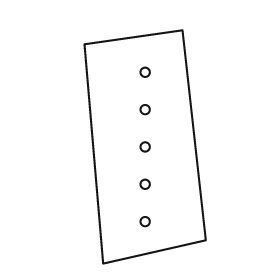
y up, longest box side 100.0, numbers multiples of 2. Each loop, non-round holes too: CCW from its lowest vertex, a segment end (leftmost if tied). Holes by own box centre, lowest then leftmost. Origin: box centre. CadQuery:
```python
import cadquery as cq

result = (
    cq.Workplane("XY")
    .moveTo(-18.0, -50.0)
    .lineTo(26.0, -40.0)
    .lineTo(16.0, 50.0)
    .lineTo(-26.0, 44.0)
    .close()
    .moveTo(0.0, -32.0)
    .circle(2.0)
    .moveTo(0.0, -16.0)
    .circle(2.0)
    .moveTo(0.0, 0.0)
    .circle(2.0)
    .moveTo(0.0, 16.0)
    .circle(2.0)
    .moveTo(0.0, 32.0)
    .circle(2.0)
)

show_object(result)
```